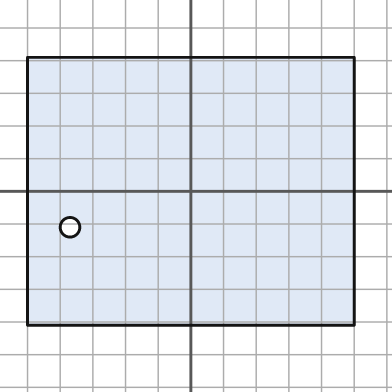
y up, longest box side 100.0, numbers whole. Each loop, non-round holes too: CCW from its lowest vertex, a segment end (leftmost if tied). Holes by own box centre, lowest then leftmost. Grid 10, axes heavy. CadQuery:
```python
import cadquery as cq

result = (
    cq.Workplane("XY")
    .moveTo(-50.0, -41.0)
    .lineTo(50.0, -41.0)
    .lineTo(50.0, 41.0)
    .lineTo(-50.0, 41.0)
    .close()
    .moveTo(-37.0, -11.0)
    .circle(3.0)
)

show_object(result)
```